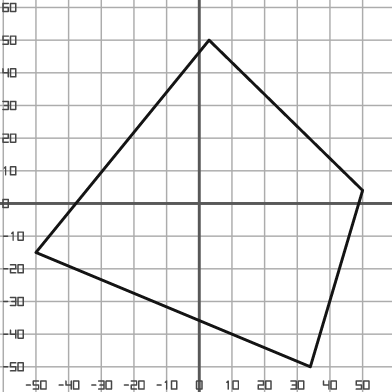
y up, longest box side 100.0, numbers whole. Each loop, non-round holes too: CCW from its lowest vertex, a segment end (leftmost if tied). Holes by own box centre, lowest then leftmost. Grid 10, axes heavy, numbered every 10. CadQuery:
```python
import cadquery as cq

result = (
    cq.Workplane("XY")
    .moveTo(34.0, -50.0)
    .lineTo(50.0, 4.0)
    .lineTo(3.0, 50.0)
    .lineTo(-50.0, -15.0)
    .close()
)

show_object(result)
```